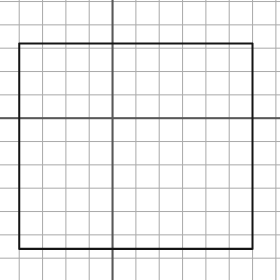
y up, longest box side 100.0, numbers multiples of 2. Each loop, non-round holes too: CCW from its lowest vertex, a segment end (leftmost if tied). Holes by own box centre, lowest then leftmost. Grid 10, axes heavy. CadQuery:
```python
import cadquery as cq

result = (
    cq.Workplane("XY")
    .moveTo(-40.0, -56.0)
    .lineTo(60.0, -56.0)
    .lineTo(60.0, 32.0)
    .lineTo(-40.0, 32.0)
    .close()
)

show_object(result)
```